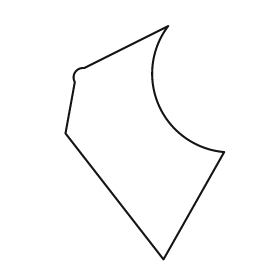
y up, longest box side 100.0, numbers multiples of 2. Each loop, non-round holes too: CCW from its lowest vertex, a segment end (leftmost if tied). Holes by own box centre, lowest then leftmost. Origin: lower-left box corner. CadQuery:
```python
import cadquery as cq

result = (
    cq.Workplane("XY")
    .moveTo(42.0, 0.0)
    .lineTo(68.0, 46.0)
    .threePointArc((40.0, 66.0), (44.0, 100.0))
    .lineTo(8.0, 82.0)
    .threePointArc((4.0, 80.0), (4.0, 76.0))
    .lineTo(0.0, 54.0)
    .close()
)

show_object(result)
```